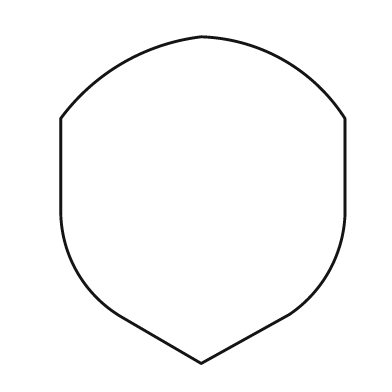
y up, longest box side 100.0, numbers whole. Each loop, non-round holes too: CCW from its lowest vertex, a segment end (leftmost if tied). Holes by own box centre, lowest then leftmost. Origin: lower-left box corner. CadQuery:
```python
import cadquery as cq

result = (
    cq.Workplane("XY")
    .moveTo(43.0, 0.0)
    .lineTo(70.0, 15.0)
    .threePointArc((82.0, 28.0), (87.0, 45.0))
    .lineTo(87.0, 75.0)
    .threePointArc((68.0, 93.0), (43.0, 100.0))
    .threePointArc((19.0, 92.0), (0.0, 75.0))
    .lineTo(0.0, 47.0)
    .threePointArc((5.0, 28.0), (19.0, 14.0))
    .close()
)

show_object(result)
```